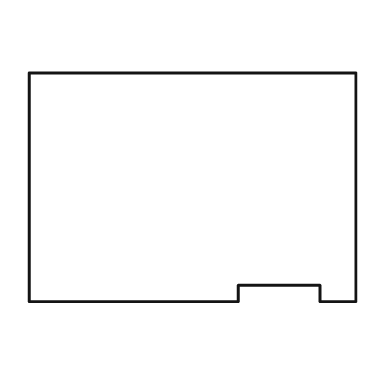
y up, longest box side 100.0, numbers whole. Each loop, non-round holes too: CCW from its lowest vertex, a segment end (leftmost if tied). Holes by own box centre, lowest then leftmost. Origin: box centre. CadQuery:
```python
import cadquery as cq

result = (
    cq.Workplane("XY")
    .moveTo(-50.0, -35.0)
    .lineTo(14.0, -35.0)
    .lineTo(14.0, -30.0)
    .lineTo(39.0, -30.0)
    .lineTo(39.0, -35.0)
    .lineTo(50.0, -35.0)
    .lineTo(50.0, 35.0)
    .lineTo(-50.0, 35.0)
    .close()
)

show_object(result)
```